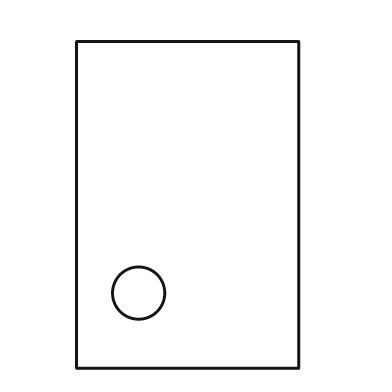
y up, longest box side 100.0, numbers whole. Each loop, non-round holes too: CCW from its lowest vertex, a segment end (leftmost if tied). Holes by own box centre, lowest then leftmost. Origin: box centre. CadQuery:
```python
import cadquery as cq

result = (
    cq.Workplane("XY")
    .moveTo(-34.0, -50.0)
    .lineTo(34.0, -50.0)
    .lineTo(34.0, 50.0)
    .lineTo(-34.0, 50.0)
    .close()
    .moveTo(-15.0, -27.0)
    .circle(8.0)
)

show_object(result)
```